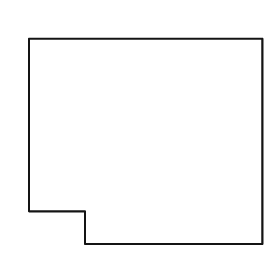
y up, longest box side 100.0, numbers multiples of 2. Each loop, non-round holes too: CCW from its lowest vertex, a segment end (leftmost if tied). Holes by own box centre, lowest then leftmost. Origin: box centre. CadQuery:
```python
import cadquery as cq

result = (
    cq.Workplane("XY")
    .moveTo(-26.0, -44.0)
    .lineTo(50.0, -44.0)
    .lineTo(50.0, 44.0)
    .lineTo(-50.0, 44.0)
    .lineTo(-50.0, -30.0)
    .lineTo(-26.0, -30.0)
    .close()
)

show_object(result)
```